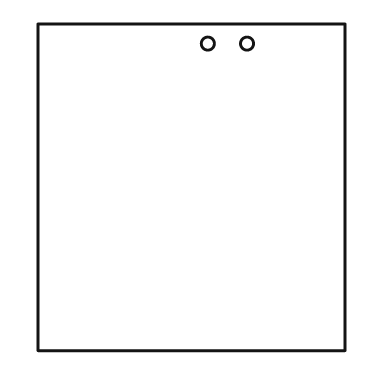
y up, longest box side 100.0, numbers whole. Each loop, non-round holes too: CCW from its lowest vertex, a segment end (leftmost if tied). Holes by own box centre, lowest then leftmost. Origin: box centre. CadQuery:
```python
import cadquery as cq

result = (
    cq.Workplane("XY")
    .moveTo(-47.0, -50.0)
    .lineTo(47.0, -50.0)
    .lineTo(47.0, 50.0)
    .lineTo(-47.0, 50.0)
    .close()
    .moveTo(5.0, 44.0)
    .circle(2.0)
    .moveTo(17.0, 44.0)
    .circle(2.0)
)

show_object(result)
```